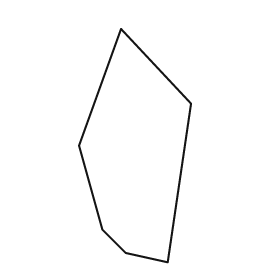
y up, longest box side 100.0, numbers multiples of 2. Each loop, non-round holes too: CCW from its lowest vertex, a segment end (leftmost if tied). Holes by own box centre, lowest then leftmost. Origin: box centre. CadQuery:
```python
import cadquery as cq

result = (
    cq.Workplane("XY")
    .moveTo(14.0, -50.0)
    .lineTo(24.0, 18.0)
    .lineTo(-6.0, 50.0)
    .lineTo(-24.0, 0.0)
    .lineTo(-14.0, -36.0)
    .lineTo(-4.0, -46.0)
    .close()
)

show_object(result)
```